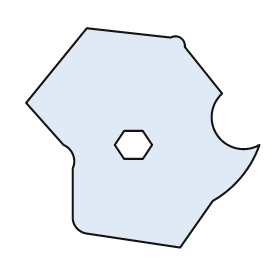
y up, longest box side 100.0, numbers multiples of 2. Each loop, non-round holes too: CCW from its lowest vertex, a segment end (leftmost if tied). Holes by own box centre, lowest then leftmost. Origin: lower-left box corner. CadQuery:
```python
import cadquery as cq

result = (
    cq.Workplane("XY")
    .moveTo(66.0, 0.0)
    .lineTo(80.0, 20.0)
    .threePointArc((92.0, 30.0), (100.0, 44.0))
    .threePointArc((82.0, 48.0), (84.0, 66.0))
    .lineTo(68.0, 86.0)
    .threePointArc((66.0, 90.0), (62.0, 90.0))
    .lineTo(26.0, 94.0)
    .lineTo(0.0, 62.0)
    .lineTo(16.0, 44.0)
    .threePointArc((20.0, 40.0), (20.0, 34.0))
    .lineTo(20.0, 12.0)
    .threePointArc((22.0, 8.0), (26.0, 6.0))
    .close()
    .moveTo(42.0, 38.0)
    .lineTo(50.0, 38.0)
    .lineTo(54.0, 44.0)
    .lineTo(50.0, 50.0)
    .lineTo(42.0, 50.0)
    .lineTo(38.0, 44.0)
    .close()
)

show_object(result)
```